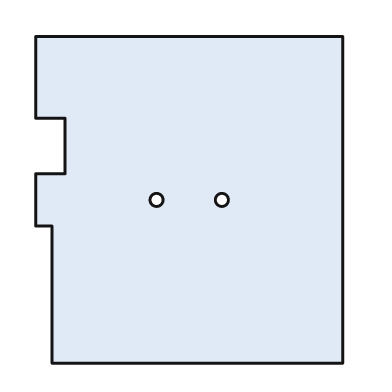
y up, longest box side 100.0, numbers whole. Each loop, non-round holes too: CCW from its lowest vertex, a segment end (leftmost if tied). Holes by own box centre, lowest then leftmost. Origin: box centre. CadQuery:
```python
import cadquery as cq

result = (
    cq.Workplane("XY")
    .moveTo(-42.0, -50.0)
    .lineTo(47.0, -50.0)
    .lineTo(47.0, 50.0)
    .lineTo(-47.0, 50.0)
    .lineTo(-47.0, 25.0)
    .lineTo(-38.0, 25.0)
    .lineTo(-38.0, 8.0)
    .lineTo(-47.0, 8.0)
    .lineTo(-47.0, -8.0)
    .lineTo(-42.0, -8.0)
    .close()
    .moveTo(-10.0, 0.0)
    .circle(2.0)
    .moveTo(10.0, 0.0)
    .circle(2.0)
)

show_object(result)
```